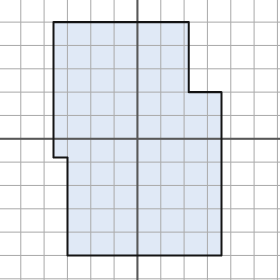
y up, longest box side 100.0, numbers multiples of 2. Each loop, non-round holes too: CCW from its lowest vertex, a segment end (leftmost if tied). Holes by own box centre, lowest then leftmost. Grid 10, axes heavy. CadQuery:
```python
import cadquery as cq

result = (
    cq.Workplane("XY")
    .moveTo(-30.0, -50.0)
    .lineTo(36.0, -50.0)
    .lineTo(36.0, 20.0)
    .lineTo(22.0, 20.0)
    .lineTo(22.0, 50.0)
    .lineTo(-36.0, 50.0)
    .lineTo(-36.0, -8.0)
    .lineTo(-30.0, -8.0)
    .close()
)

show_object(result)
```